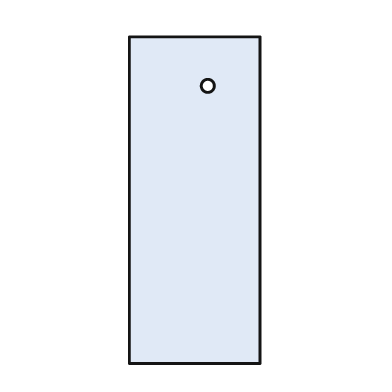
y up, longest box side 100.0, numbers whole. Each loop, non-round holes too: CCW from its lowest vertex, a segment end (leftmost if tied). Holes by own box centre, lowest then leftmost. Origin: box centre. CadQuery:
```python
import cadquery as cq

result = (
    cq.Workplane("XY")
    .moveTo(-20.0, -50.0)
    .lineTo(20.0, -50.0)
    .lineTo(20.0, 50.0)
    .lineTo(-20.0, 50.0)
    .close()
    .moveTo(4.0, 35.0)
    .circle(2.0)
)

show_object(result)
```